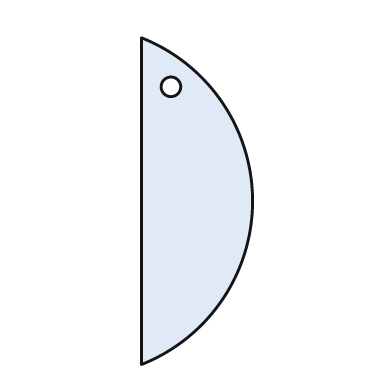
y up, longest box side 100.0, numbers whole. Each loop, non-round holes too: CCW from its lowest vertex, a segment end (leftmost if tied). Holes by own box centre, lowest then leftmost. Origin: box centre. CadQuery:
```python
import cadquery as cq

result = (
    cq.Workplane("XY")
    .moveTo(-17.0, -50.0)
    .threePointArc((17.0, 0.0), (-17.0, 50.0))
    .close()
    .moveTo(-8.0, 35.0)
    .circle(3.0)
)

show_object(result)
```